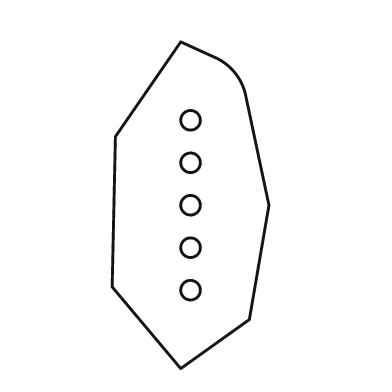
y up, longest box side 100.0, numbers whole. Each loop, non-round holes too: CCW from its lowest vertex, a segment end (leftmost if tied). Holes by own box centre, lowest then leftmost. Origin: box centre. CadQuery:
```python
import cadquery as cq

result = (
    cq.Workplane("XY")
    .moveTo(-3.0, -50.0)
    .lineTo(18.0, -35.0)
    .lineTo(24.0, 0.0)
    .lineTo(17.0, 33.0)
    .threePointArc((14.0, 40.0), (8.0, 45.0))
    .lineTo(-3.0, 50.0)
    .lineTo(-23.0, 21.0)
    .lineTo(-24.0, -25.0)
    .close()
    .moveTo(0.0, -26.0)
    .circle(3.0)
    .moveTo(0.0, -13.0)
    .circle(3.0)
    .moveTo(0.0, 0.0)
    .circle(3.0)
    .moveTo(0.0, 13.0)
    .circle(3.0)
    .moveTo(0.0, 26.0)
    .circle(3.0)
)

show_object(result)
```